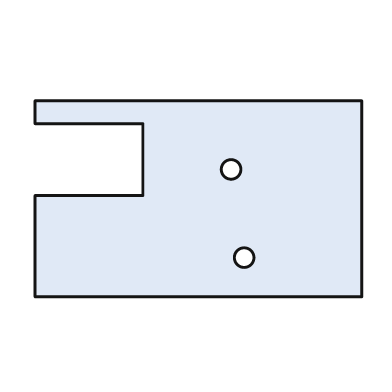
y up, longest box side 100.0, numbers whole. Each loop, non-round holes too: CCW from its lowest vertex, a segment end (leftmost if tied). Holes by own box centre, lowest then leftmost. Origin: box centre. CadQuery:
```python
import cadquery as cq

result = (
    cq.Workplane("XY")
    .moveTo(-50.0, -30.0)
    .lineTo(50.0, -30.0)
    .lineTo(50.0, 30.0)
    .lineTo(-50.0, 30.0)
    .lineTo(-50.0, 23.0)
    .lineTo(-17.0, 23.0)
    .lineTo(-17.0, 1.0)
    .lineTo(-50.0, 1.0)
    .close()
    .moveTo(14.0, -18.0)
    .circle(3.0)
    .moveTo(10.0, 9.0)
    .circle(3.0)
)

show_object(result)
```